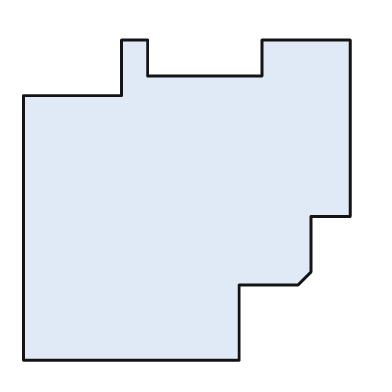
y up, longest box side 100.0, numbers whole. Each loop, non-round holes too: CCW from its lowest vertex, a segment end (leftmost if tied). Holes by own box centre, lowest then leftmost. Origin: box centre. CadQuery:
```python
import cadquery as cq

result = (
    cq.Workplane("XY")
    .moveTo(-50.0, -49.0)
    .lineTo(16.0, -49.0)
    .lineTo(16.0, -26.0)
    .lineTo(34.0, -26.0)
    .lineTo(38.0, -22.0)
    .lineTo(38.0, -5.0)
    .lineTo(50.0, -5.0)
    .lineTo(50.0, 49.0)
    .lineTo(23.0, 49.0)
    .lineTo(23.0, 38.0)
    .lineTo(-12.0, 38.0)
    .lineTo(-12.0, 49.0)
    .lineTo(-20.0, 49.0)
    .lineTo(-20.0, 32.0)
    .lineTo(-50.0, 32.0)
    .close()
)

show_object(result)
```